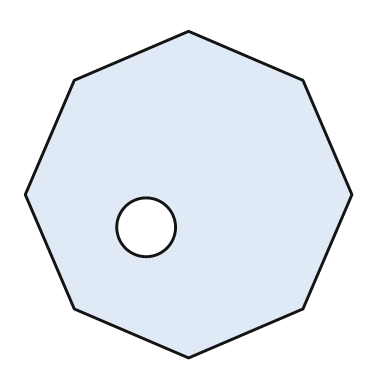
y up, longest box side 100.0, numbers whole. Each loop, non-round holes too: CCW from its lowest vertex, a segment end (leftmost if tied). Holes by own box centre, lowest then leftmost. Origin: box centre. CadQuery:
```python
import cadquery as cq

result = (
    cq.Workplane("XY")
    .moveTo(0.0, -50.0)
    .lineTo(35.0, -35.0)
    .lineTo(50.0, 0.0)
    .lineTo(35.0, 35.0)
    .lineTo(0.0, 50.0)
    .lineTo(-35.0, 35.0)
    .lineTo(-50.0, 0.0)
    .lineTo(-35.0, -35.0)
    .close()
    .moveTo(-13.0, -10.0)
    .circle(9.0)
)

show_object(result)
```